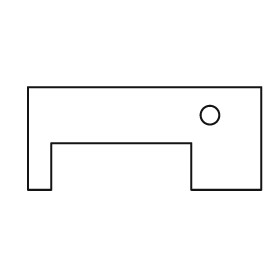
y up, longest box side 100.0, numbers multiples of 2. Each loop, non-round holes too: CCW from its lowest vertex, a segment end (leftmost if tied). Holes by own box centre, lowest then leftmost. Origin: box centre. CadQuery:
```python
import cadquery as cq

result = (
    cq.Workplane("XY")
    .moveTo(-50.0, -22.0)
    .lineTo(-40.0, -22.0)
    .lineTo(-40.0, -2.0)
    .lineTo(20.0, -2.0)
    .lineTo(20.0, -22.0)
    .lineTo(50.0, -22.0)
    .lineTo(50.0, 22.0)
    .lineTo(-50.0, 22.0)
    .close()
    .moveTo(28.0, 10.0)
    .circle(4.0)
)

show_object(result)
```